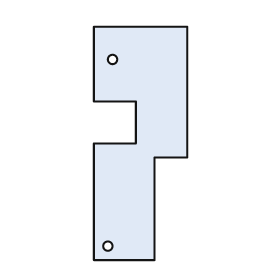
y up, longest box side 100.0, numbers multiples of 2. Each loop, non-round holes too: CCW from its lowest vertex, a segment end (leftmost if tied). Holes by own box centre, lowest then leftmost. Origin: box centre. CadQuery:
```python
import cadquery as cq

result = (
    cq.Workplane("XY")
    .moveTo(-20.0, -50.0)
    .lineTo(6.0, -50.0)
    .lineTo(6.0, -6.0)
    .lineTo(20.0, -6.0)
    .lineTo(20.0, 50.0)
    .lineTo(-20.0, 50.0)
    .lineTo(-20.0, 18.0)
    .lineTo(-2.0, 18.0)
    .lineTo(-2.0, 0.0)
    .lineTo(-20.0, 0.0)
    .close()
    .moveTo(-14.0, -44.0)
    .circle(2.0)
    .moveTo(-12.0, 36.0)
    .circle(2.0)
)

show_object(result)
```